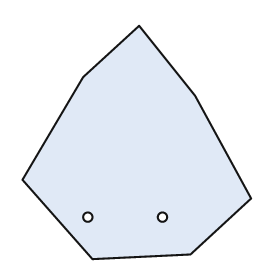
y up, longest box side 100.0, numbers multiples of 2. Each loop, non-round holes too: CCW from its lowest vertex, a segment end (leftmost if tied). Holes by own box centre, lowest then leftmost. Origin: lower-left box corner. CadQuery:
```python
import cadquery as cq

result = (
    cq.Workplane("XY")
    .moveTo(30.0, 0.0)
    .lineTo(72.0, 2.0)
    .lineTo(98.0, 26.0)
    .lineTo(74.0, 70.0)
    .lineTo(50.0, 100.0)
    .lineTo(26.0, 78.0)
    .lineTo(0.0, 34.0)
    .close()
    .moveTo(28.0, 18.0)
    .circle(2.0)
    .moveTo(60.0, 18.0)
    .circle(2.0)
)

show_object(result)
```